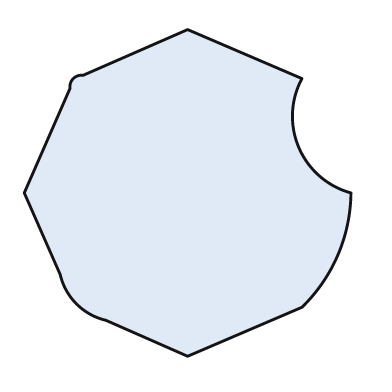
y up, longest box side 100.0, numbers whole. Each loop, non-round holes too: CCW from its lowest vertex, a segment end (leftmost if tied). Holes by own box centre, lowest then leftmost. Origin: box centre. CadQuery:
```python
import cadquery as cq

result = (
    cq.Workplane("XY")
    .moveTo(0.0, -50.0)
    .lineTo(35.0, -35.0)
    .threePointArc((46.0, -19.0), (50.0, 0.0))
    .threePointArc((34.0, 14.0), (35.0, 35.0))
    .lineTo(0.0, 50.0)
    .lineTo(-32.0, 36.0)
    .threePointArc((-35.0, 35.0), (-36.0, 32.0))
    .lineTo(-50.0, 0.0)
    .lineTo(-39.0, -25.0)
    .threePointArc((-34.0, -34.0), (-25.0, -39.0))
    .close()
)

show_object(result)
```